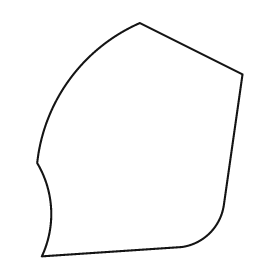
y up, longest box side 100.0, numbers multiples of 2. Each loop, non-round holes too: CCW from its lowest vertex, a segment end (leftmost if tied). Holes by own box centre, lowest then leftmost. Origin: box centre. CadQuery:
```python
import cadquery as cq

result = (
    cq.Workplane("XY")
    .moveTo(-42.0, -50.0)
    .lineTo(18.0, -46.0)
    .threePointArc((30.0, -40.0), (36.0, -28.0))
    .lineTo(44.0, 28.0)
    .lineTo(0.0, 50.0)
    .threePointArc((-30.0, 26.0), (-44.0, -10.0))
    .threePointArc((-38.0, -30.0), (-42.0, -50.0))
    .close()
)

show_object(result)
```